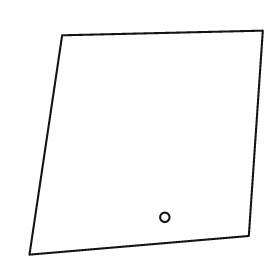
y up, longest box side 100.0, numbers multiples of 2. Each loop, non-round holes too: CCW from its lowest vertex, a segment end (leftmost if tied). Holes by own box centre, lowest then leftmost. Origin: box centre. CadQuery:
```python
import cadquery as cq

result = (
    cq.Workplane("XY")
    .moveTo(-50.0, -48.0)
    .lineTo(44.0, -40.0)
    .lineTo(50.0, 48.0)
    .lineTo(-36.0, 46.0)
    .close()
    .moveTo(8.0, -32.0)
    .circle(2.0)
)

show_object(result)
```